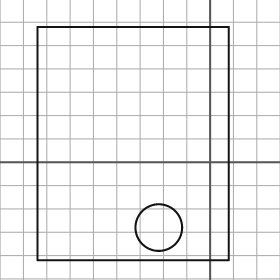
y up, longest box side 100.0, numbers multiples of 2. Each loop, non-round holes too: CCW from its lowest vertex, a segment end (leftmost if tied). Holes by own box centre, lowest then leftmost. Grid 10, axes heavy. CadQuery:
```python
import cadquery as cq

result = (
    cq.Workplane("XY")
    .moveTo(-74.0, -42.0)
    .lineTo(8.0, -42.0)
    .lineTo(8.0, 58.0)
    .lineTo(-74.0, 58.0)
    .close()
    .moveTo(-22.0, -28.0)
    .circle(10.0)
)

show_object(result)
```